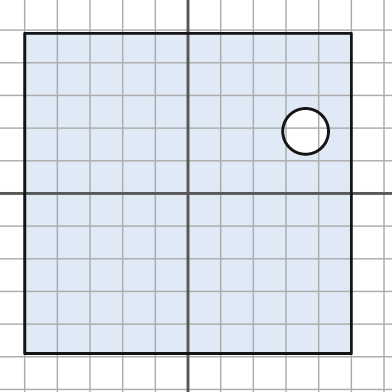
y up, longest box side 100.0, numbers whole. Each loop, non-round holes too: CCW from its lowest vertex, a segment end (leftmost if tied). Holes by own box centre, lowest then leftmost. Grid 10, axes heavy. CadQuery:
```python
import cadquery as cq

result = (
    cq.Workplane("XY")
    .moveTo(-50.0, -49.0)
    .lineTo(50.0, -49.0)
    .lineTo(50.0, 49.0)
    .lineTo(-50.0, 49.0)
    .close()
    .moveTo(36.0, 19.0)
    .circle(7.0)
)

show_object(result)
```